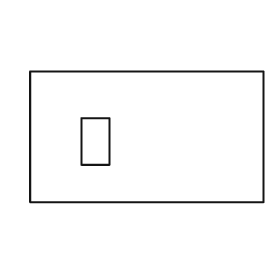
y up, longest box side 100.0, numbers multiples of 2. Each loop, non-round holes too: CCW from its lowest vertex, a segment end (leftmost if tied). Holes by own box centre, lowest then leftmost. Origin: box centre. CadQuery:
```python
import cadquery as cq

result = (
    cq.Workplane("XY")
    .moveTo(-50.0, -28.0)
    .lineTo(50.0, -28.0)
    .lineTo(50.0, 28.0)
    .lineTo(-50.0, 28.0)
    .close()
    .moveTo(-28.0, -12.0)
    .lineTo(-16.0, -12.0)
    .lineTo(-16.0, 8.0)
    .lineTo(-28.0, 8.0)
    .close()
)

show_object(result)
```